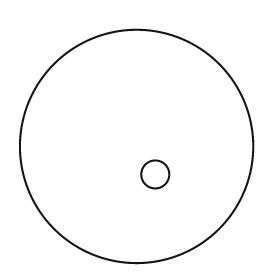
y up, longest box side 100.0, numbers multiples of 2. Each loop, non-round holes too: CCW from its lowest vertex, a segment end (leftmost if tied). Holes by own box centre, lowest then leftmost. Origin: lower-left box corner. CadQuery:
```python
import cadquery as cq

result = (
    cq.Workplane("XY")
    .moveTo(50.0, 50.0)
    .circle(50.0)
    .moveTo(58.0, 38.0)
    .circle(6.0)
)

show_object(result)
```